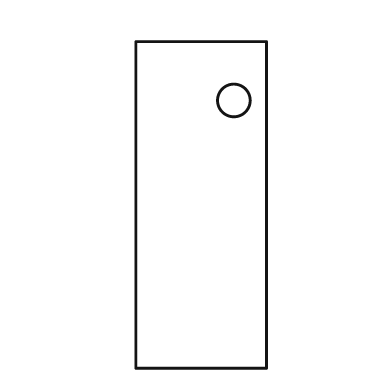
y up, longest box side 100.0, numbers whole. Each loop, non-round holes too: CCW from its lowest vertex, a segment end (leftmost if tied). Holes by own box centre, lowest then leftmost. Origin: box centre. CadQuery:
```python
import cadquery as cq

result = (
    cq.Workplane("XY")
    .moveTo(-20.0, -50.0)
    .lineTo(20.0, -50.0)
    .lineTo(20.0, 50.0)
    .lineTo(-20.0, 50.0)
    .close()
    .moveTo(10.0, 32.0)
    .circle(5.0)
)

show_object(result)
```